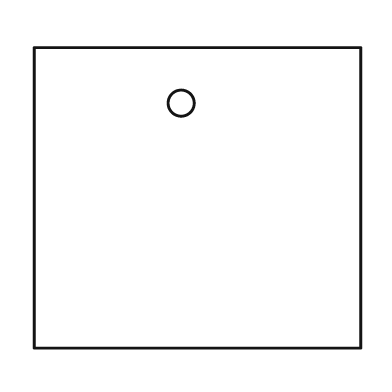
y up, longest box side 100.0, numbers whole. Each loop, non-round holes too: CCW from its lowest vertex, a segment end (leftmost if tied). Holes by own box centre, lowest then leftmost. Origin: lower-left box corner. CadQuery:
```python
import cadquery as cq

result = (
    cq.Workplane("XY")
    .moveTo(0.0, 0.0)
    .lineTo(100.0, 0.0)
    .lineTo(100.0, 92.0)
    .lineTo(0.0, 92.0)
    .close()
    .moveTo(45.0, 75.0)
    .circle(4.0)
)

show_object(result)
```